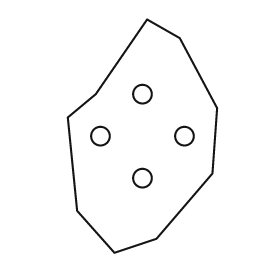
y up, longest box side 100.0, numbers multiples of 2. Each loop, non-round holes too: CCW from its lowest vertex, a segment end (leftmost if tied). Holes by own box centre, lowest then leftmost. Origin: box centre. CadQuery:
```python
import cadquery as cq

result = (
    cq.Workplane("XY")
    .moveTo(-12.0, -50.0)
    .lineTo(6.0, -44.0)
    .lineTo(30.0, -16.0)
    .lineTo(32.0, 12.0)
    .lineTo(16.0, 42.0)
    .lineTo(2.0, 50.0)
    .lineTo(-20.0, 18.0)
    .lineTo(-32.0, 8.0)
    .lineTo(-28.0, -32.0)
    .close()
    .moveTo(0.0, -18.0)
    .circle(4.0)
    .moveTo(-18.0, 0.0)
    .circle(4.0)
    .moveTo(18.0, 0.0)
    .circle(4.0)
    .moveTo(0.0, 18.0)
    .circle(4.0)
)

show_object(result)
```